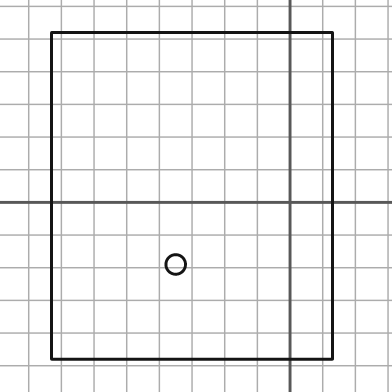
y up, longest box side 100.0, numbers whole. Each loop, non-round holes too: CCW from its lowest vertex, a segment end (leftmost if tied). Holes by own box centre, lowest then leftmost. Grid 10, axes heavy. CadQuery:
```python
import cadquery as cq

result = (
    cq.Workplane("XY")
    .moveTo(-73.0, -48.0)
    .lineTo(13.0, -48.0)
    .lineTo(13.0, 52.0)
    .lineTo(-73.0, 52.0)
    .close()
    .moveTo(-35.0, -19.0)
    .circle(3.0)
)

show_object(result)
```